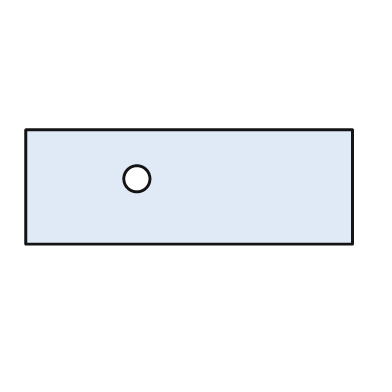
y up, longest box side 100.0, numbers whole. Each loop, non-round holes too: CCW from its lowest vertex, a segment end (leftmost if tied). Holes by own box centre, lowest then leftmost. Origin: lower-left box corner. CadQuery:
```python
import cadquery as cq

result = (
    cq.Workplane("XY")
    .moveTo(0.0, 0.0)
    .lineTo(100.0, 0.0)
    .lineTo(100.0, 35.0)
    .lineTo(0.0, 35.0)
    .close()
    .moveTo(34.0, 20.0)
    .circle(4.0)
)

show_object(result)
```